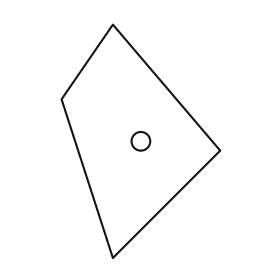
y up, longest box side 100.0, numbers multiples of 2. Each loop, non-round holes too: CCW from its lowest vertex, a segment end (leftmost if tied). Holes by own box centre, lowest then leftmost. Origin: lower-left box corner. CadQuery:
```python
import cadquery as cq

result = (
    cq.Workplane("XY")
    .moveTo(22.0, 0.0)
    .lineTo(68.0, 46.0)
    .lineTo(22.0, 100.0)
    .lineTo(0.0, 68.0)
    .close()
    .moveTo(34.0, 50.0)
    .circle(4.0)
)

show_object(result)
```